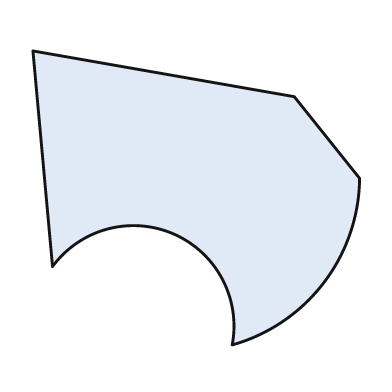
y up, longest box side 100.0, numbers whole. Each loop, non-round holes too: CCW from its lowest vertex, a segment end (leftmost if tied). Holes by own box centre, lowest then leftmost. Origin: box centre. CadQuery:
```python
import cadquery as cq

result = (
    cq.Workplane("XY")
    .moveTo(11.0, -45.0)
    .threePointArc((39.0, -26.0), (50.0, 6.0))
    .lineTo(30.0, 31.0)
    .lineTo(-50.0, 45.0)
    .lineTo(-44.0, -21.0)
    .threePointArc((-7.0, -11.0), (11.0, -45.0))
    .close()
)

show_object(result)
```